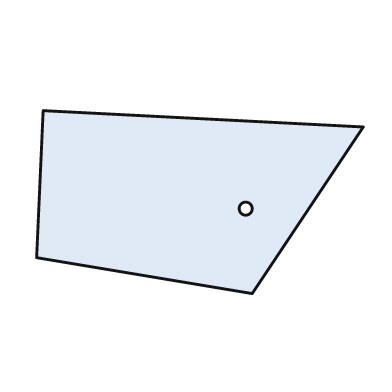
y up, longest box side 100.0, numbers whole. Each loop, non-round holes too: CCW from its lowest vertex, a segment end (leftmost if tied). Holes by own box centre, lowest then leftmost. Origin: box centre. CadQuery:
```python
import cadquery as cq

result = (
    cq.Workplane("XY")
    .moveTo(16.0, -28.0)
    .lineTo(50.0, 23.0)
    .lineTo(-48.0, 28.0)
    .lineTo(-50.0, -17.0)
    .close()
    .moveTo(14.0, -2.0)
    .circle(2.0)
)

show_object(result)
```